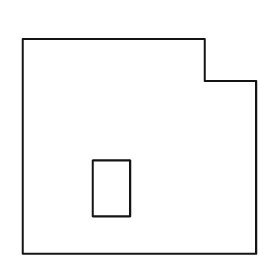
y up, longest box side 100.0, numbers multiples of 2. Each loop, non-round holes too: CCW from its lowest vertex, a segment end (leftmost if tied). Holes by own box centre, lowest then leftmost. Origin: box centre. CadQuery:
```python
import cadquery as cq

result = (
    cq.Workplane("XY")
    .moveTo(-50.0, -46.0)
    .lineTo(50.0, -46.0)
    .lineTo(50.0, 28.0)
    .lineTo(28.0, 28.0)
    .lineTo(28.0, 46.0)
    .lineTo(-50.0, 46.0)
    .close()
    .moveTo(-20.0, -30.0)
    .lineTo(-4.0, -30.0)
    .lineTo(-4.0, -6.0)
    .lineTo(-20.0, -6.0)
    .close()
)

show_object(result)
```